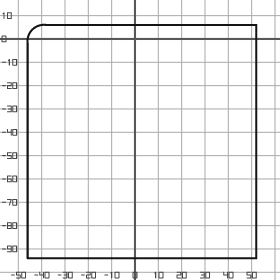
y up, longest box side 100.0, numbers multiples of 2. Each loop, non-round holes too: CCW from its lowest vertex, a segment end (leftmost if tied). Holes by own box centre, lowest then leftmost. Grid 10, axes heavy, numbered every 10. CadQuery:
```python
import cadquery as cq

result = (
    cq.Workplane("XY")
    .moveTo(-46.0, -94.0)
    .lineTo(52.0, -94.0)
    .lineTo(52.0, 6.0)
    .lineTo(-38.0, 6.0)
    .threePointArc((-44.0, 4.0), (-46.0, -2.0))
    .close()
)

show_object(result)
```